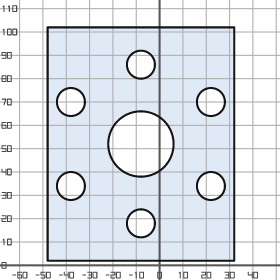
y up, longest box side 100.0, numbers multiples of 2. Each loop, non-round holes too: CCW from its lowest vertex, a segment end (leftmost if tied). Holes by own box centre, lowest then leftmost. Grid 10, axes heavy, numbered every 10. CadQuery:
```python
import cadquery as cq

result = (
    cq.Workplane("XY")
    .moveTo(-48.0, 2.0)
    .lineTo(32.0, 2.0)
    .lineTo(32.0, 102.0)
    .lineTo(-48.0, 102.0)
    .close()
    .moveTo(-8.0, 18.0)
    .circle(6.0)
    .moveTo(-38.0, 34.0)
    .circle(6.0)
    .moveTo(22.0, 34.0)
    .circle(6.0)
    .moveTo(-8.0, 52.0)
    .circle(14.0)
    .moveTo(-38.0, 70.0)
    .circle(6.0)
    .moveTo(22.0, 70.0)
    .circle(6.0)
    .moveTo(-8.0, 86.0)
    .circle(6.0)
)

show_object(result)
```